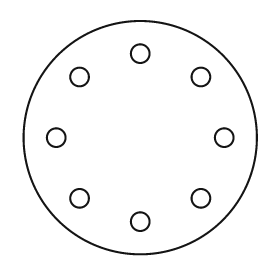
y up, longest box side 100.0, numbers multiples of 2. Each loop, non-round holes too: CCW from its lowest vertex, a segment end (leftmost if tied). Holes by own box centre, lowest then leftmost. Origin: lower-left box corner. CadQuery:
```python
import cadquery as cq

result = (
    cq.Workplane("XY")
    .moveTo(50.0, 50.0)
    .circle(50.0)
    .moveTo(50.0, 14.0)
    .circle(4.0)
    .moveTo(24.0, 24.0)
    .circle(4.0)
    .moveTo(76.0, 24.0)
    .circle(4.0)
    .moveTo(14.0, 50.0)
    .circle(4.0)
    .moveTo(86.0, 50.0)
    .circle(4.0)
    .moveTo(24.0, 76.0)
    .circle(4.0)
    .moveTo(76.0, 76.0)
    .circle(4.0)
    .moveTo(50.0, 86.0)
    .circle(4.0)
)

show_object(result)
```